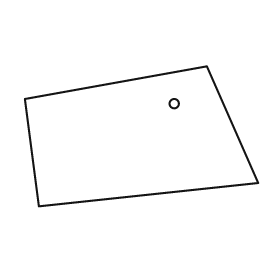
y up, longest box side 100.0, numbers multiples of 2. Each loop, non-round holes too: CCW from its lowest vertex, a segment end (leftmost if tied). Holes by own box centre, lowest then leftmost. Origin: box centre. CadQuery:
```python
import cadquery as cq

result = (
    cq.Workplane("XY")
    .moveTo(-44.0, -30.0)
    .lineTo(50.0, -20.0)
    .lineTo(28.0, 30.0)
    .lineTo(-50.0, 16.0)
    .close()
    .moveTo(14.0, 14.0)
    .circle(2.0)
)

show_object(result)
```